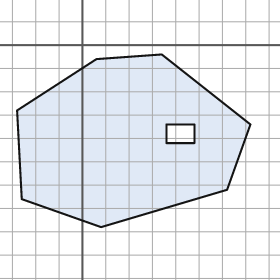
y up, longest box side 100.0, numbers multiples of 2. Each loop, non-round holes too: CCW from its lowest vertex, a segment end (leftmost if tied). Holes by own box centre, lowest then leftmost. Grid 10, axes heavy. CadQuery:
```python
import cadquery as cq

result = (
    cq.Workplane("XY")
    .moveTo(8.0, -78.0)
    .lineTo(62.0, -62.0)
    .lineTo(72.0, -34.0)
    .lineTo(34.0, -4.0)
    .lineTo(6.0, -6.0)
    .lineTo(-28.0, -28.0)
    .lineTo(-26.0, -66.0)
    .close()
    .moveTo(36.0, -42.0)
    .lineTo(48.0, -42.0)
    .lineTo(48.0, -34.0)
    .lineTo(36.0, -34.0)
    .close()
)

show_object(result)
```